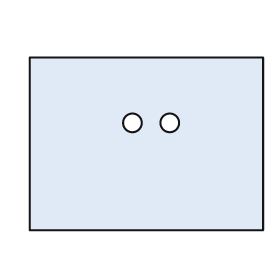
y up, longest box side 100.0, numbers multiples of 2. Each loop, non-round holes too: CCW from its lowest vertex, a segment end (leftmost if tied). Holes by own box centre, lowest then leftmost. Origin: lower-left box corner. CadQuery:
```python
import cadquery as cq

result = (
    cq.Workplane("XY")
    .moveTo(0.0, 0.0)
    .lineTo(100.0, 0.0)
    .lineTo(100.0, 74.0)
    .lineTo(0.0, 74.0)
    .close()
    .moveTo(44.0, 46.0)
    .circle(4.0)
    .moveTo(60.0, 46.0)
    .circle(4.0)
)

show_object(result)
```